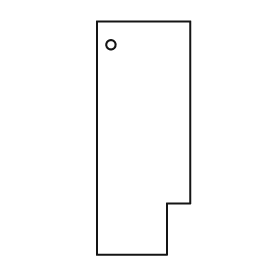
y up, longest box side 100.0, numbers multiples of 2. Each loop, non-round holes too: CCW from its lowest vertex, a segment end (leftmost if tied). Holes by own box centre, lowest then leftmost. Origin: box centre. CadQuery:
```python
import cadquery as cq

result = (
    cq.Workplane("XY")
    .moveTo(-20.0, -50.0)
    .lineTo(10.0, -50.0)
    .lineTo(10.0, -28.0)
    .lineTo(20.0, -28.0)
    .lineTo(20.0, 50.0)
    .lineTo(-20.0, 50.0)
    .close()
    .moveTo(-14.0, 40.0)
    .circle(2.0)
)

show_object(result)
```